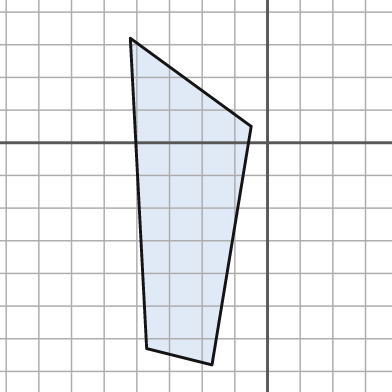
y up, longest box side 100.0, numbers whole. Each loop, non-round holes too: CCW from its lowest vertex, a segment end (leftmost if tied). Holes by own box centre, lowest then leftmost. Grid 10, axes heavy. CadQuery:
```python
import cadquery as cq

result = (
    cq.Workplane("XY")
    .moveTo(-17.0, -68.0)
    .lineTo(-5.0, 5.0)
    .lineTo(-42.0, 32.0)
    .lineTo(-37.0, -63.0)
    .close()
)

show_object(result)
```